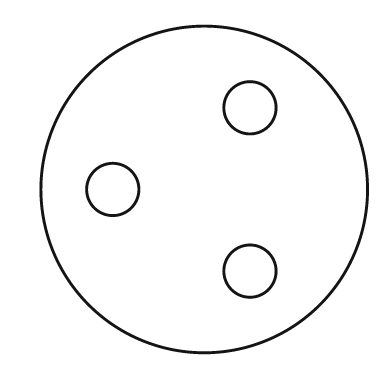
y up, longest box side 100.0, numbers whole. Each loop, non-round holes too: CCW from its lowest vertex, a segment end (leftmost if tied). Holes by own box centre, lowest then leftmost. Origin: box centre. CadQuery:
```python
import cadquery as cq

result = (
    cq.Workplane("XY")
    .moveTo(0.0, 0.0)
    .circle(50.0)
    .moveTo(14.0, -25.0)
    .circle(8.0)
    .moveTo(-28.0, 0.0)
    .circle(8.0)
    .moveTo(14.0, 25.0)
    .circle(8.0)
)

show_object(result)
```